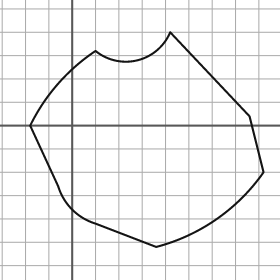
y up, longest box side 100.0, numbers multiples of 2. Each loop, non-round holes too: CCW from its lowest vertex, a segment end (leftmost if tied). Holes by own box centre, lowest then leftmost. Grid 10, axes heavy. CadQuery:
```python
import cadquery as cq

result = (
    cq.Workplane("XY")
    .moveTo(36.0, -52.0)
    .threePointArc((62.0, -40.0), (82.0, -20.0))
    .lineTo(76.0, 4.0)
    .lineTo(42.0, 40.0)
    .threePointArc((28.0, 28.0), (10.0, 32.0))
    .threePointArc((-6.0, 18.0), (-18.0, 0.0))
    .lineTo(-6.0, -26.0)
    .threePointArc((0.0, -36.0), (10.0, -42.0))
    .close()
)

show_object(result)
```